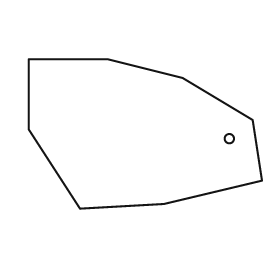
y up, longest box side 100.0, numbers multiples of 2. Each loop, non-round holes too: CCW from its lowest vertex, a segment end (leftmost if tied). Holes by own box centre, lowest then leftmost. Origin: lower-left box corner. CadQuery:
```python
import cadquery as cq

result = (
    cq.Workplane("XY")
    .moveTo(22.0, 0.0)
    .lineTo(58.0, 2.0)
    .lineTo(100.0, 12.0)
    .lineTo(96.0, 38.0)
    .lineTo(66.0, 56.0)
    .lineTo(34.0, 64.0)
    .lineTo(0.0, 64.0)
    .lineTo(0.0, 34.0)
    .close()
    .moveTo(86.0, 30.0)
    .circle(2.0)
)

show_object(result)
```